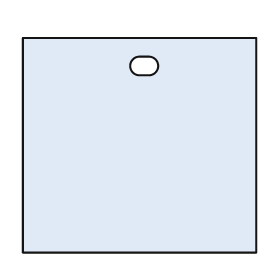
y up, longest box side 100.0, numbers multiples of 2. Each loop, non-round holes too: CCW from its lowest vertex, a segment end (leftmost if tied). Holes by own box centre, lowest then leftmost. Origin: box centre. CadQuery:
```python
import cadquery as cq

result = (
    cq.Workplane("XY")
    .moveTo(-50.0, -46.0)
    .lineTo(50.0, -46.0)
    .lineTo(50.0, 46.0)
    .lineTo(-50.0, 46.0)
    .close()
    .moveTo(0.0, 30.0)
    .lineTo(4.0, 30.0)
    .threePointArc((8.0, 34.0), (4.0, 38.0))
    .lineTo(0.0, 38.0)
    .threePointArc((-4.0, 34.0), (0.0, 30.0))
    .close()
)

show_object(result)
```